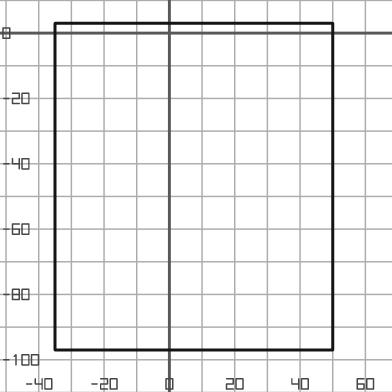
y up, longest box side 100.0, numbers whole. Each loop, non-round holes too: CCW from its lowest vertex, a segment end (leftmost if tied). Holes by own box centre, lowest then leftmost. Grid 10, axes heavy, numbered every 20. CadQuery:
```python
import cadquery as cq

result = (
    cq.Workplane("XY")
    .moveTo(-35.0, -97.0)
    .lineTo(50.0, -97.0)
    .lineTo(50.0, 3.0)
    .lineTo(-35.0, 3.0)
    .close()
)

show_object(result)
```